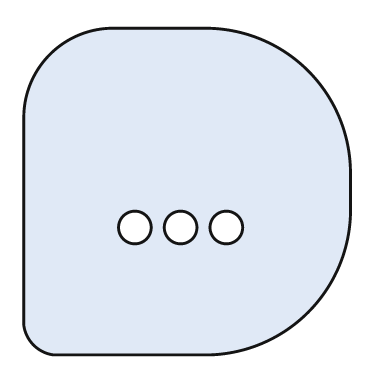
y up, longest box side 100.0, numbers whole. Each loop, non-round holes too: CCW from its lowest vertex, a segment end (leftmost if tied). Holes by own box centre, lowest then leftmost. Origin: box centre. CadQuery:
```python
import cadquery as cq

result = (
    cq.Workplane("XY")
    .moveTo(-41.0, -50.0)
    .lineTo(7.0, -50.0)
    .threePointArc((37.0, -37.0), (50.0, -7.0))
    .lineTo(50.0, 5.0)
    .threePointArc((37.0, 37.0), (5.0, 50.0))
    .lineTo(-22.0, 50.0)
    .threePointArc((-42.0, 42.0), (-50.0, 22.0))
    .lineTo(-50.0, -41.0)
    .threePointArc((-47.0, -47.0), (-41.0, -50.0))
    .close()
    .moveTo(-16.0, -11.0)
    .circle(5.0)
    .moveTo(-2.0, -11.0)
    .circle(5.0)
    .moveTo(12.0, -11.0)
    .circle(5.0)
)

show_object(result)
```